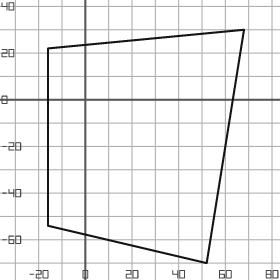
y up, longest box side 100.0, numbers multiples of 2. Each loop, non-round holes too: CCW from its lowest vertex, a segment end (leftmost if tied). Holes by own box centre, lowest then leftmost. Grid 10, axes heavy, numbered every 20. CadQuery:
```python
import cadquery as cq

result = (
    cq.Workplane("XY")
    .moveTo(52.0, -70.0)
    .lineTo(68.0, 30.0)
    .lineTo(-16.0, 22.0)
    .lineTo(-16.0, -54.0)
    .close()
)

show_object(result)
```